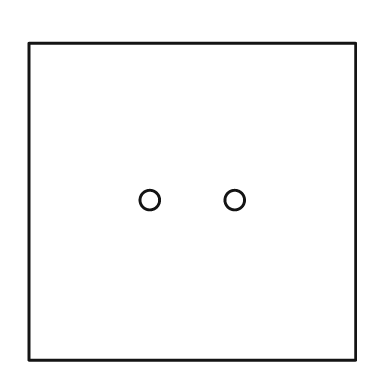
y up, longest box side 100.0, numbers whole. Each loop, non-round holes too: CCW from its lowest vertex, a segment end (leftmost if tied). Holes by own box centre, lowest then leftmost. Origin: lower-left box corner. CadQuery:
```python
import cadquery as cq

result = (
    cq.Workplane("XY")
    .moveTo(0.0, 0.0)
    .lineTo(100.0, 0.0)
    .lineTo(100.0, 97.0)
    .lineTo(0.0, 97.0)
    .close()
    .moveTo(37.0, 49.0)
    .circle(3.0)
    .moveTo(63.0, 49.0)
    .circle(3.0)
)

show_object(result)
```